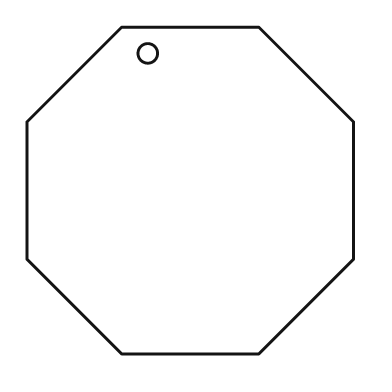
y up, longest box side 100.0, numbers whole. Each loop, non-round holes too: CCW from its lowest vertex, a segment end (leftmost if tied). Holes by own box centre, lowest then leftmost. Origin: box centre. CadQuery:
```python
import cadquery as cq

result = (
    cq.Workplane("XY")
    .moveTo(-21.0, -50.0)
    .lineTo(21.0, -50.0)
    .lineTo(50.0, -21.0)
    .lineTo(50.0, 21.0)
    .lineTo(21.0, 50.0)
    .lineTo(-21.0, 50.0)
    .lineTo(-50.0, 21.0)
    .lineTo(-50.0, -21.0)
    .close()
    .moveTo(-13.0, 42.0)
    .circle(3.0)
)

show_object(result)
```